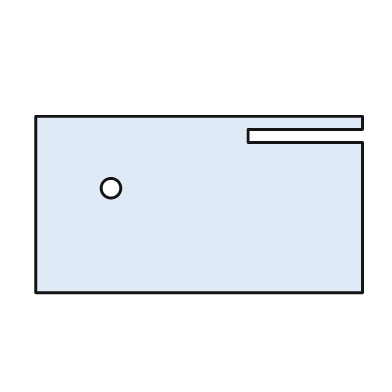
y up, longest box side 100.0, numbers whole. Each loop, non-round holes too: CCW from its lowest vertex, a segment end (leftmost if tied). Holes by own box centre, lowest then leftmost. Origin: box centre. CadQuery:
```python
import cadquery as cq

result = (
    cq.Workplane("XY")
    .moveTo(-50.0, -27.0)
    .lineTo(50.0, -27.0)
    .lineTo(50.0, 19.0)
    .lineTo(15.0, 19.0)
    .lineTo(15.0, 23.0)
    .lineTo(50.0, 23.0)
    .lineTo(50.0, 27.0)
    .lineTo(-50.0, 27.0)
    .close()
    .moveTo(-27.0, 5.0)
    .circle(3.0)
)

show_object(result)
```